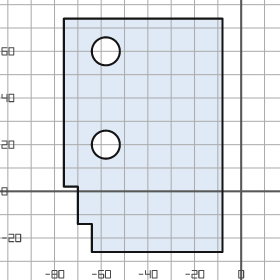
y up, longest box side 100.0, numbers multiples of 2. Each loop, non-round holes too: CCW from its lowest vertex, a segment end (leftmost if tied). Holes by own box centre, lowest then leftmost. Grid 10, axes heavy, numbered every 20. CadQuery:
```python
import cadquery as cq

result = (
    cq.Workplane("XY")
    .moveTo(-64.0, -26.0)
    .lineTo(-8.0, -26.0)
    .lineTo(-8.0, 74.0)
    .lineTo(-76.0, 74.0)
    .lineTo(-76.0, 2.0)
    .lineTo(-70.0, 2.0)
    .lineTo(-70.0, -14.0)
    .lineTo(-64.0, -14.0)
    .close()
    .moveTo(-58.0, 20.0)
    .circle(6.0)
    .moveTo(-58.0, 60.0)
    .circle(6.0)
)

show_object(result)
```